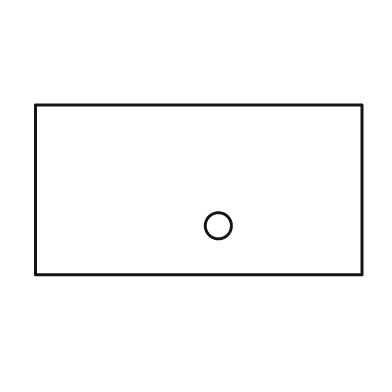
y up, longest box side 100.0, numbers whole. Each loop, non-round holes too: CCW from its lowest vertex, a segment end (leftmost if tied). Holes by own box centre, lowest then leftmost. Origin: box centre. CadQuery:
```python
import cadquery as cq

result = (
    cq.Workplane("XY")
    .moveTo(-50.0, -26.0)
    .lineTo(50.0, -26.0)
    .lineTo(50.0, 26.0)
    .lineTo(-50.0, 26.0)
    .close()
    .moveTo(6.0, -11.0)
    .circle(4.0)
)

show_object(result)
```